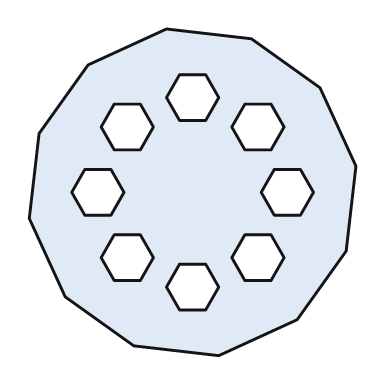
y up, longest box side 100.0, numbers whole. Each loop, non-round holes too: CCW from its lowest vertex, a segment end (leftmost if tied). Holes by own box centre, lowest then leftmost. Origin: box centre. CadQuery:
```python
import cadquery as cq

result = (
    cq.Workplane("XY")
    .moveTo(8.0, -50.0)
    .lineTo(32.0, -39.0)
    .lineTo(47.0, -18.0)
    .lineTo(50.0, 8.0)
    .lineTo(39.0, 32.0)
    .lineTo(18.0, 47.0)
    .lineTo(-8.0, 50.0)
    .lineTo(-32.0, 39.0)
    .lineTo(-47.0, 18.0)
    .lineTo(-50.0, -8.0)
    .lineTo(-39.0, -32.0)
    .lineTo(-18.0, -47.0)
    .close()
    .moveTo(-4.0, -36.0)
    .lineTo(4.0, -36.0)
    .lineTo(8.0, -29.0)
    .lineTo(4.0, -22.0)
    .lineTo(-4.0, -22.0)
    .lineTo(-8.0, -29.0)
    .close()
    .moveTo(-24.0, -27.0)
    .lineTo(-16.0, -27.0)
    .lineTo(-12.0, -20.0)
    .lineTo(-16.0, -13.0)
    .lineTo(-24.0, -13.0)
    .lineTo(-28.0, -20.0)
    .close()
    .moveTo(16.0, -27.0)
    .lineTo(24.0, -27.0)
    .lineTo(28.0, -20.0)
    .lineTo(24.0, -13.0)
    .lineTo(16.0, -13.0)
    .lineTo(12.0, -20.0)
    .close()
    .moveTo(-33.0, -7.0)
    .lineTo(-25.0, -7.0)
    .lineTo(-21.0, 0.0)
    .lineTo(-25.0, 7.0)
    .lineTo(-33.0, 7.0)
    .lineTo(-37.0, 0.0)
    .close()
    .moveTo(25.0, -7.0)
    .lineTo(33.0, -7.0)
    .lineTo(37.0, 0.0)
    .lineTo(33.0, 7.0)
    .lineTo(25.0, 7.0)
    .lineTo(21.0, 0.0)
    .close()
    .moveTo(-24.0, 13.0)
    .lineTo(-16.0, 13.0)
    .lineTo(-12.0, 20.0)
    .lineTo(-16.0, 27.0)
    .lineTo(-24.0, 27.0)
    .lineTo(-28.0, 20.0)
    .close()
    .moveTo(16.0, 13.0)
    .lineTo(24.0, 13.0)
    .lineTo(28.0, 20.0)
    .lineTo(24.0, 27.0)
    .lineTo(16.0, 27.0)
    .lineTo(12.0, 20.0)
    .close()
    .moveTo(-4.0, 22.0)
    .lineTo(4.0, 22.0)
    .lineTo(8.0, 29.0)
    .lineTo(4.0, 36.0)
    .lineTo(-4.0, 36.0)
    .lineTo(-8.0, 29.0)
    .close()
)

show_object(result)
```